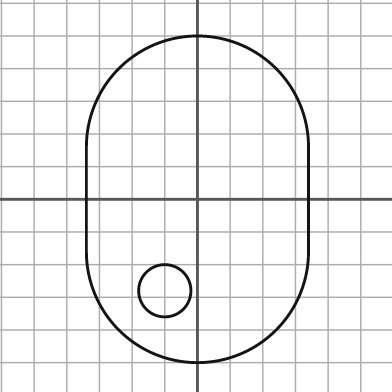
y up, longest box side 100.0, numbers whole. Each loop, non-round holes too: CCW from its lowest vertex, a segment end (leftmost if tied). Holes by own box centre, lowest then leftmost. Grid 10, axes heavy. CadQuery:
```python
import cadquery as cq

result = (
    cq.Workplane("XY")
    .moveTo(-34.0, -16.0)
    .threePointArc((0.0, -50.0), (34.0, -16.0))
    .lineTo(34.0, 16.0)
    .threePointArc((0.0, 50.0), (-34.0, 16.0))
    .close()
    .moveTo(-10.0, -28.0)
    .circle(8.0)
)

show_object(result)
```